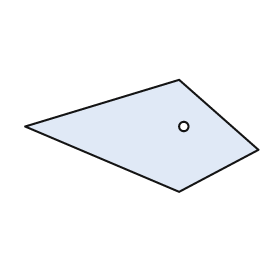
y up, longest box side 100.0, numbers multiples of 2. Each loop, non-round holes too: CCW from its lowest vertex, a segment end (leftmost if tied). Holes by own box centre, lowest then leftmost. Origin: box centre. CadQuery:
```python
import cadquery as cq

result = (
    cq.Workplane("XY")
    .moveTo(16.0, -24.0)
    .lineTo(50.0, -6.0)
    .lineTo(16.0, 24.0)
    .lineTo(-50.0, 4.0)
    .close()
    .moveTo(18.0, 4.0)
    .circle(2.0)
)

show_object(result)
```